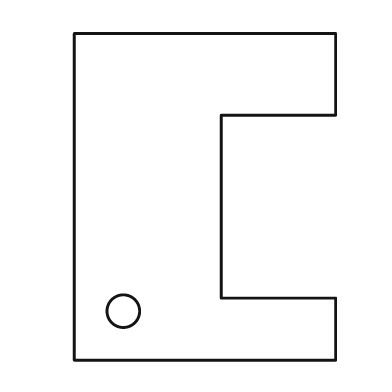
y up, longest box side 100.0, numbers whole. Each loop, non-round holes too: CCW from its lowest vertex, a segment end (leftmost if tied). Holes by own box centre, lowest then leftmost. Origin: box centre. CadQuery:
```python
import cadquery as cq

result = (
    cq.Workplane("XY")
    .moveTo(-40.0, -50.0)
    .lineTo(40.0, -50.0)
    .lineTo(40.0, -31.0)
    .lineTo(5.0, -31.0)
    .lineTo(5.0, 25.0)
    .lineTo(40.0, 25.0)
    .lineTo(40.0, 50.0)
    .lineTo(-40.0, 50.0)
    .close()
    .moveTo(-25.0, -35.0)
    .circle(5.0)
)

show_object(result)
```